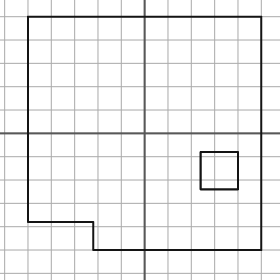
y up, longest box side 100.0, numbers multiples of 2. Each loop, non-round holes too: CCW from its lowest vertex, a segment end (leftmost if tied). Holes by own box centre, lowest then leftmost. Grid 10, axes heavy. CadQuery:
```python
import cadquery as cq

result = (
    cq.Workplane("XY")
    .moveTo(-22.0, -50.0)
    .lineTo(50.0, -50.0)
    .lineTo(50.0, 50.0)
    .lineTo(-50.0, 50.0)
    .lineTo(-50.0, -38.0)
    .lineTo(-22.0, -38.0)
    .close()
    .moveTo(24.0, -24.0)
    .lineTo(40.0, -24.0)
    .lineTo(40.0, -8.0)
    .lineTo(24.0, -8.0)
    .close()
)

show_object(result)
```